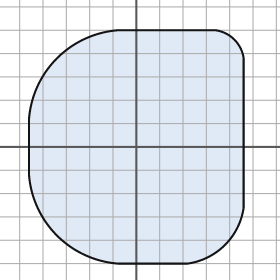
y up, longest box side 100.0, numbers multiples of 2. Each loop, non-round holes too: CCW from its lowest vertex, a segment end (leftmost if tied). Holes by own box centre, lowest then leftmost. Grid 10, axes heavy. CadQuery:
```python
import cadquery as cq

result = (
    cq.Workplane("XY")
    .moveTo(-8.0, -50.0)
    .lineTo(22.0, -50.0)
    .threePointArc((38.0, -42.0), (46.0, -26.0))
    .lineTo(46.0, 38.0)
    .threePointArc((42.0, 46.0), (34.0, 50.0))
    .lineTo(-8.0, 50.0)
    .threePointArc((-34.0, 38.0), (-46.0, 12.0))
    .lineTo(-46.0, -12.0)
    .threePointArc((-34.0, -38.0), (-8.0, -50.0))
    .close()
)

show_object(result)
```